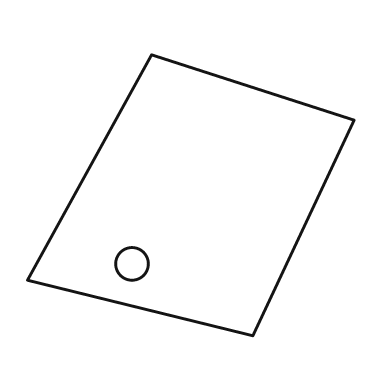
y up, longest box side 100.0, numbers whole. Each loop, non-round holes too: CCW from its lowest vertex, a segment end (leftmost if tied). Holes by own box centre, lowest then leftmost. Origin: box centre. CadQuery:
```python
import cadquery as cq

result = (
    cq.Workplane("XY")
    .moveTo(19.0, -43.0)
    .lineTo(50.0, 23.0)
    .lineTo(-12.0, 43.0)
    .lineTo(-50.0, -26.0)
    .close()
    .moveTo(-18.0, -21.0)
    .circle(5.0)
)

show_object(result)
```